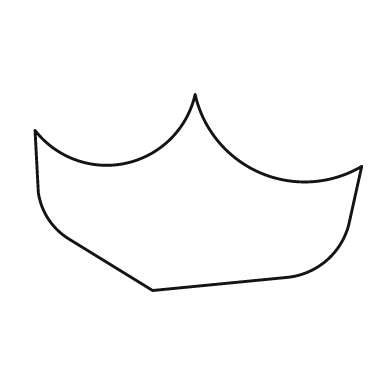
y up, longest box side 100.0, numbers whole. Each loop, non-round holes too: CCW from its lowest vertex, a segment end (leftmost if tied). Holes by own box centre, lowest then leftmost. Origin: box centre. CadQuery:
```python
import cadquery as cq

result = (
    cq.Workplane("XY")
    .moveTo(-14.0, -30.0)
    .lineTo(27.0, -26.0)
    .threePointArc((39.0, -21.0), (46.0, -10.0))
    .lineTo(50.0, 8.0)
    .threePointArc((19.0, 6.0), (-1.0, 30.0))
    .threePointArc((-22.0, 9.0), (-50.0, 19.0))
    .lineTo(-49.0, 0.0)
    .threePointArc((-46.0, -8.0), (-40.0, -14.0))
    .close()
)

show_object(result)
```